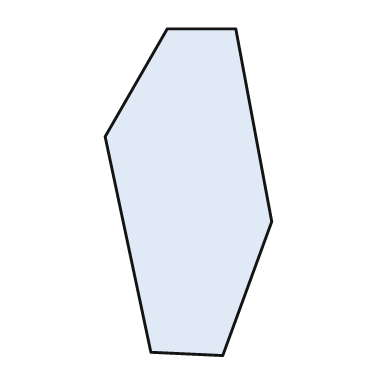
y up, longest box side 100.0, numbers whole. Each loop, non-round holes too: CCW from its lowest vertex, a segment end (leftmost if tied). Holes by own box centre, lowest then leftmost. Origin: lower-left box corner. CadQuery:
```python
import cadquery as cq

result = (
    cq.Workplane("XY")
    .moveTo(36.0, 0.0)
    .lineTo(51.0, 41.0)
    .lineTo(40.0, 100.0)
    .lineTo(19.0, 100.0)
    .lineTo(0.0, 67.0)
    .lineTo(14.0, 1.0)
    .close()
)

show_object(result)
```